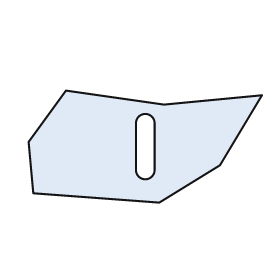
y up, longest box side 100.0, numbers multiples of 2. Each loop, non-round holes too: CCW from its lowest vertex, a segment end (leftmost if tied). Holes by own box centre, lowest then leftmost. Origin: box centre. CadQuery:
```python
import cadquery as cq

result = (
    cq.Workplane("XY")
    .moveTo(6.0, -24.0)
    .lineTo(32.0, -8.0)
    .lineTo(50.0, 22.0)
    .lineTo(8.0, 18.0)
    .lineTo(-34.0, 24.0)
    .lineTo(-50.0, 2.0)
    .lineTo(-48.0, -20.0)
    .close()
    .moveTo(-4.0, -10.0)
    .threePointArc((0.0, -14.0), (4.0, -10.0))
    .lineTo(4.0, 10.0)
    .threePointArc((0.0, 14.0), (-4.0, 10.0))
    .close()
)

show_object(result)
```